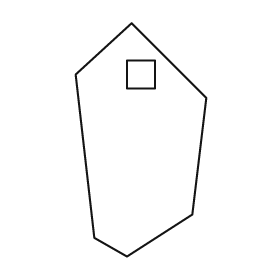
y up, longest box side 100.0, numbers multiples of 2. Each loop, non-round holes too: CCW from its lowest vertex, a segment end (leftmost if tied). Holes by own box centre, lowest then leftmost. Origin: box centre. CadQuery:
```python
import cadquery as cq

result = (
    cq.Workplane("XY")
    .moveTo(-6.0, -50.0)
    .lineTo(22.0, -32.0)
    .lineTo(28.0, 18.0)
    .lineTo(-4.0, 50.0)
    .lineTo(-28.0, 28.0)
    .lineTo(-20.0, -42.0)
    .close()
    .moveTo(-6.0, 22.0)
    .lineTo(6.0, 22.0)
    .lineTo(6.0, 34.0)
    .lineTo(-6.0, 34.0)
    .close()
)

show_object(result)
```